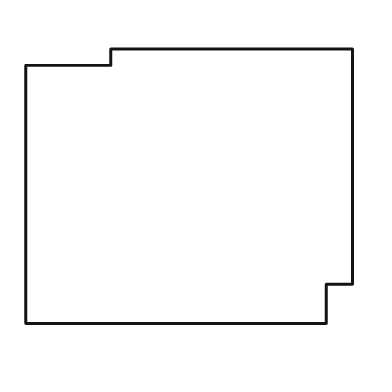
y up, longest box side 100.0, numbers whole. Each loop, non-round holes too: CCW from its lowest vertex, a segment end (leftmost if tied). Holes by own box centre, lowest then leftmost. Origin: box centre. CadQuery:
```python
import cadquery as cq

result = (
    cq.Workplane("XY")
    .moveTo(-50.0, -42.0)
    .lineTo(42.0, -42.0)
    .lineTo(42.0, -30.0)
    .lineTo(50.0, -30.0)
    .lineTo(50.0, 42.0)
    .lineTo(-24.0, 42.0)
    .lineTo(-24.0, 37.0)
    .lineTo(-50.0, 37.0)
    .close()
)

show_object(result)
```